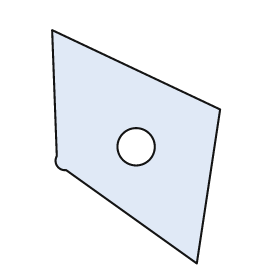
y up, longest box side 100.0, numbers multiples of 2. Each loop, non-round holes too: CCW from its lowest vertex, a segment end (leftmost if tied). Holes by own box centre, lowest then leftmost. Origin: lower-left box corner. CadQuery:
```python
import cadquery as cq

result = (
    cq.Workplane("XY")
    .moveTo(62.0, 0.0)
    .lineTo(72.0, 66.0)
    .lineTo(0.0, 100.0)
    .lineTo(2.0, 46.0)
    .threePointArc((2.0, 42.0), (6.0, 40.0))
    .close()
    .moveTo(36.0, 50.0)
    .circle(8.0)
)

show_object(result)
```